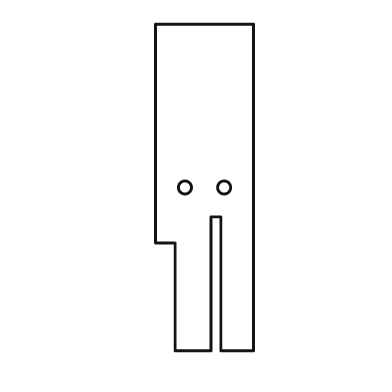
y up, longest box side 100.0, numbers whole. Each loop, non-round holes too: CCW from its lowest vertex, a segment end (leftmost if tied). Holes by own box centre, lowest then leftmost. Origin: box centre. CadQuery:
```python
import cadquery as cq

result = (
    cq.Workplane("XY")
    .moveTo(-9.0, -50.0)
    .lineTo(2.0, -50.0)
    .lineTo(2.0, -9.0)
    .lineTo(5.0, -9.0)
    .lineTo(5.0, -50.0)
    .lineTo(15.0, -50.0)
    .lineTo(15.0, 50.0)
    .lineTo(-15.0, 50.0)
    .lineTo(-15.0, -17.0)
    .lineTo(-9.0, -17.0)
    .close()
    .moveTo(-6.0, 0.0)
    .circle(2.0)
    .moveTo(6.0, 0.0)
    .circle(2.0)
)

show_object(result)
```